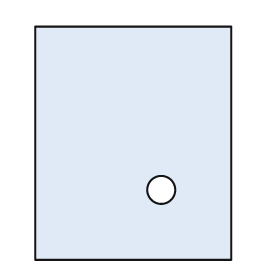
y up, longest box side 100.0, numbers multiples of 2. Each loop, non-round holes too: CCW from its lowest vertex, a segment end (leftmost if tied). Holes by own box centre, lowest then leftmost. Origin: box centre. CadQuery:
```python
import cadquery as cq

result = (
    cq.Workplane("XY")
    .moveTo(-42.0, -50.0)
    .lineTo(42.0, -50.0)
    .lineTo(42.0, 50.0)
    .lineTo(-42.0, 50.0)
    .close()
    .moveTo(12.0, -20.0)
    .circle(6.0)
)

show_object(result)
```